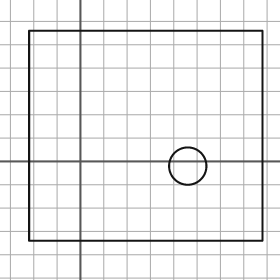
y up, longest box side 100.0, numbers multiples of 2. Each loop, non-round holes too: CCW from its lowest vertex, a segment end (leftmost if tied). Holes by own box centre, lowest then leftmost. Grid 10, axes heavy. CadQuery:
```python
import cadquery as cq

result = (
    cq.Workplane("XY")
    .moveTo(-22.0, -34.0)
    .lineTo(78.0, -34.0)
    .lineTo(78.0, 56.0)
    .lineTo(-22.0, 56.0)
    .close()
    .moveTo(46.0, -2.0)
    .circle(8.0)
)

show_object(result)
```